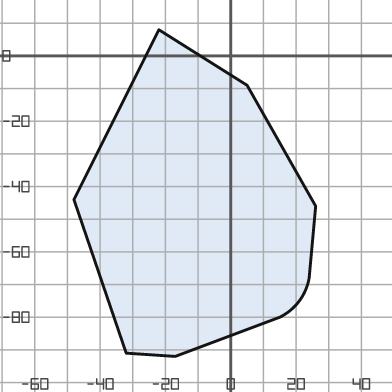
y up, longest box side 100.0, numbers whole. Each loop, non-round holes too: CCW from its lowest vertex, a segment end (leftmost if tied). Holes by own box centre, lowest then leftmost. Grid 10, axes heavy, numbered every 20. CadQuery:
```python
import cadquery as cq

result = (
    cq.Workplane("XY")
    .moveTo(-17.0, -92.0)
    .lineTo(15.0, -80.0)
    .threePointArc((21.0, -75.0), (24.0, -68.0))
    .lineTo(26.0, -46.0)
    .lineTo(5.0, -9.0)
    .lineTo(-22.0, 8.0)
    .lineTo(-48.0, -44.0)
    .lineTo(-32.0, -91.0)
    .close()
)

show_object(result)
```